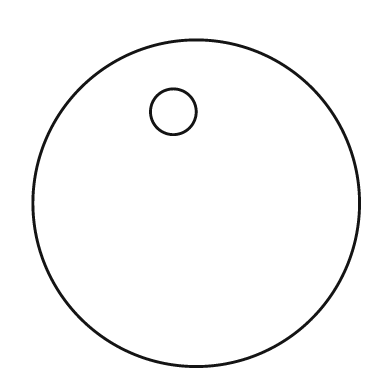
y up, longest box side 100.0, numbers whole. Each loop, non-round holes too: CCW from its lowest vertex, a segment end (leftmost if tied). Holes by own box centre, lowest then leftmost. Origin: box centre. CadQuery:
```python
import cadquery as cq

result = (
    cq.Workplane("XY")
    .moveTo(0.0, 0.0)
    .circle(50.0)
    .moveTo(-7.0, 28.0)
    .circle(7.0)
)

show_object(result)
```